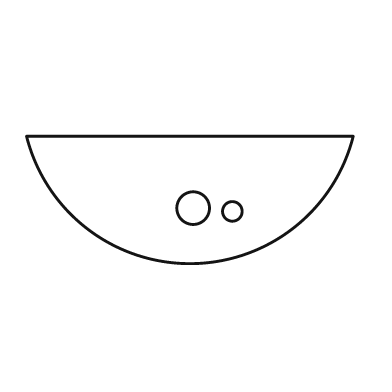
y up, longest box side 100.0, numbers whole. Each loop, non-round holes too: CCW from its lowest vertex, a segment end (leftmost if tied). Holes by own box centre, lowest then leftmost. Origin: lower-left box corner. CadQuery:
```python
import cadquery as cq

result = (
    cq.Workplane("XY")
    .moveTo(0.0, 39.0)
    .threePointArc((50.0, 0.0), (100.0, 39.0))
    .close()
    .moveTo(63.0, 16.0)
    .circle(3.0)
    .moveTo(51.0, 17.0)
    .circle(5.0)
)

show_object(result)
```